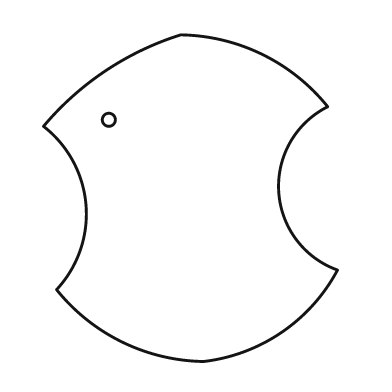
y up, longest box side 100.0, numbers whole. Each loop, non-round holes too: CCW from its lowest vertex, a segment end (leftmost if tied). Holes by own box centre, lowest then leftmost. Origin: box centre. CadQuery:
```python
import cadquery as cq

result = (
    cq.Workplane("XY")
    .moveTo(4.0, -50.0)
    .threePointArc((28.0, -41.0), (45.0, -22.0))
    .threePointArc((27.0, 2.0), (42.0, 28.0))
    .threePointArc((22.0, 44.0), (-3.0, 50.0))
    .threePointArc((-26.0, 39.0), (-45.0, 22.0))
    .threePointArc((-32.0, -2.0), (-41.0, -28.0))
    .threePointArc((-21.0, -44.0), (4.0, -50.0))
    .close()
    .moveTo(-25.0, 24.0)
    .circle(2.0)
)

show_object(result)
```